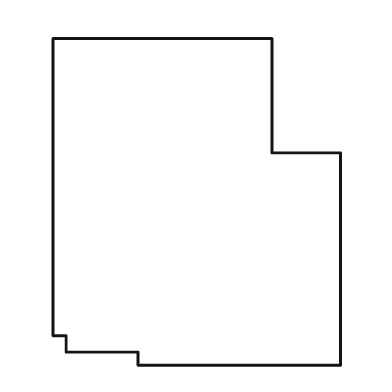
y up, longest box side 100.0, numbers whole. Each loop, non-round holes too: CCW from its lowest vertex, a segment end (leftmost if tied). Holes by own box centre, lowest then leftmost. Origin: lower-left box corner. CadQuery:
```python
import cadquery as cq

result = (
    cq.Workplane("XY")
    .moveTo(26.0, 0.0)
    .lineTo(88.0, 0.0)
    .lineTo(88.0, 65.0)
    .lineTo(67.0, 65.0)
    .lineTo(67.0, 100.0)
    .lineTo(0.0, 100.0)
    .lineTo(0.0, 9.0)
    .lineTo(4.0, 9.0)
    .lineTo(4.0, 4.0)
    .lineTo(26.0, 4.0)
    .close()
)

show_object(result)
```